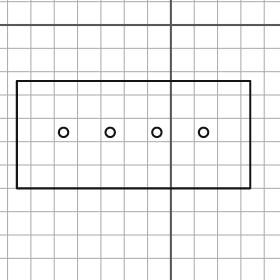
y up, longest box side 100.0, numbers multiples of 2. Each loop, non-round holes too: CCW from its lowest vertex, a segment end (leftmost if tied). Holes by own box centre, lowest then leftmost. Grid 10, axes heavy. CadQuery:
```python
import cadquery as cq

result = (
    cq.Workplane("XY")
    .moveTo(-66.0, -70.0)
    .lineTo(34.0, -70.0)
    .lineTo(34.0, -24.0)
    .lineTo(-66.0, -24.0)
    .close()
    .moveTo(-46.0, -46.0)
    .circle(2.0)
    .moveTo(-26.0, -46.0)
    .circle(2.0)
    .moveTo(-6.0, -46.0)
    .circle(2.0)
    .moveTo(14.0, -46.0)
    .circle(2.0)
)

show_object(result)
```